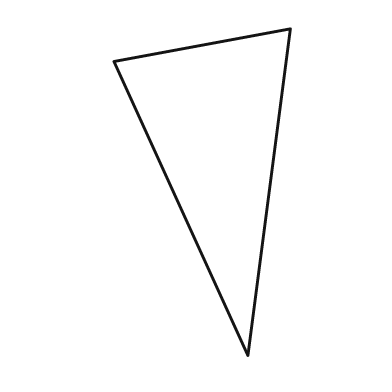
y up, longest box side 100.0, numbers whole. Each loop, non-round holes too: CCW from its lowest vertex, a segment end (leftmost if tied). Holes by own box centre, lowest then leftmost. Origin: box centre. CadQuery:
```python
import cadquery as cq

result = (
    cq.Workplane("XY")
    .moveTo(14.0, -50.0)
    .lineTo(27.0, 50.0)
    .lineTo(-27.0, 40.0)
    .close()
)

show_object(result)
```